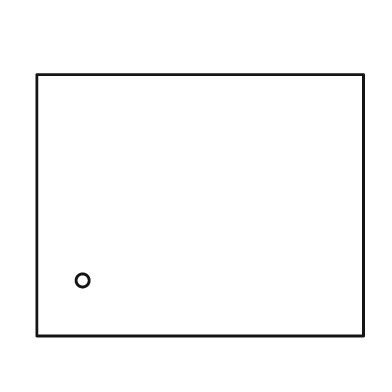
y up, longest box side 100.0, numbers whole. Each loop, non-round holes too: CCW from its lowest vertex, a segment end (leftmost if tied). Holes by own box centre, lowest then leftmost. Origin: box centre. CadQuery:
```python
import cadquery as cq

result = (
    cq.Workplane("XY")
    .moveTo(-50.0, -40.0)
    .lineTo(50.0, -40.0)
    .lineTo(50.0, 40.0)
    .lineTo(-50.0, 40.0)
    .close()
    .moveTo(-36.0, -23.0)
    .circle(2.0)
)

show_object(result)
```